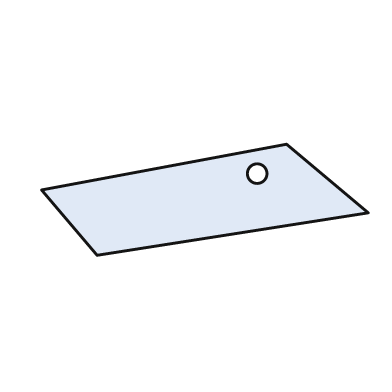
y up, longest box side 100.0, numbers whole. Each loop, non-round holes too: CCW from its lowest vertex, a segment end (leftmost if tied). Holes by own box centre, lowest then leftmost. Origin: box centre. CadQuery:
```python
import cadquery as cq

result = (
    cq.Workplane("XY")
    .moveTo(-33.0, -17.0)
    .lineTo(50.0, -4.0)
    .lineTo(25.0, 17.0)
    .lineTo(-50.0, 3.0)
    .close()
    .moveTo(16.0, 8.0)
    .circle(3.0)
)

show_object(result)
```